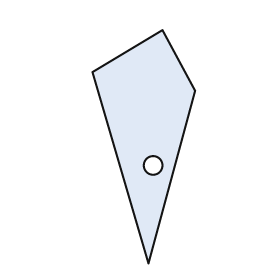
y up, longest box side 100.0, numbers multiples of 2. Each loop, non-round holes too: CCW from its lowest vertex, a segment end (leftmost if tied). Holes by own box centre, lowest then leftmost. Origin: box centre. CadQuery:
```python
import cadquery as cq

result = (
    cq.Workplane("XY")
    .moveTo(2.0, -50.0)
    .lineTo(22.0, 24.0)
    .lineTo(8.0, 50.0)
    .lineTo(-22.0, 32.0)
    .close()
    .moveTo(4.0, -8.0)
    .circle(4.0)
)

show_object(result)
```